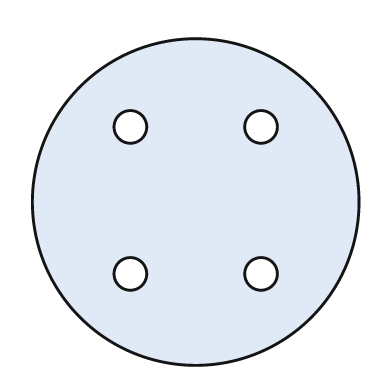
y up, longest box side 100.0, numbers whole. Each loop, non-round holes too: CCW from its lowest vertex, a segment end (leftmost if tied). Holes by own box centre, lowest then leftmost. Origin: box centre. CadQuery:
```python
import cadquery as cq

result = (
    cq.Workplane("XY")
    .moveTo(0.0, 0.0)
    .circle(50.0)
    .moveTo(-20.0, -22.0)
    .circle(5.0)
    .moveTo(20.0, -22.0)
    .circle(5.0)
    .moveTo(-20.0, 23.0)
    .circle(5.0)
    .moveTo(20.0, 23.0)
    .circle(5.0)
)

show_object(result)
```